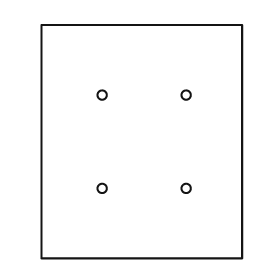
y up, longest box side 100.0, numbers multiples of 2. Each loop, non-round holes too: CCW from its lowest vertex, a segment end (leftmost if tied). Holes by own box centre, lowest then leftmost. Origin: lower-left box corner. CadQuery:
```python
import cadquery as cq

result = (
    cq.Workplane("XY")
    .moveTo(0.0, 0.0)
    .lineTo(86.0, 0.0)
    .lineTo(86.0, 100.0)
    .lineTo(0.0, 100.0)
    .close()
    .moveTo(26.0, 30.0)
    .circle(2.0)
    .moveTo(62.0, 30.0)
    .circle(2.0)
    .moveTo(26.0, 70.0)
    .circle(2.0)
    .moveTo(62.0, 70.0)
    .circle(2.0)
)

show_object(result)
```